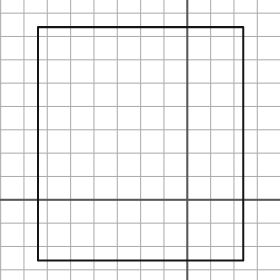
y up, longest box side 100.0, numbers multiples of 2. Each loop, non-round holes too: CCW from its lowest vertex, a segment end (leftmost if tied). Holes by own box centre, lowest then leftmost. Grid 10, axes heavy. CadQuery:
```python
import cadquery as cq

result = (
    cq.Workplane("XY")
    .moveTo(-64.0, -26.0)
    .lineTo(24.0, -26.0)
    .lineTo(24.0, 74.0)
    .lineTo(-64.0, 74.0)
    .close()
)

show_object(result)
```